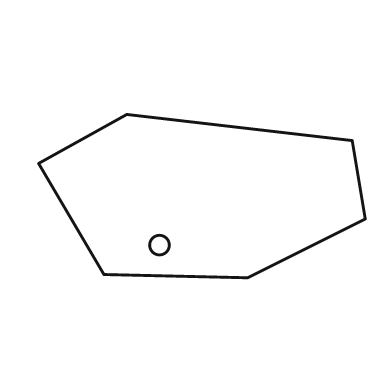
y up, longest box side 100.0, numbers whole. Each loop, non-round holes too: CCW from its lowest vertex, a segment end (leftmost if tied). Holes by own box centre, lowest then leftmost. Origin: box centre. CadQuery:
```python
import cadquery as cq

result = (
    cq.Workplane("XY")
    .moveTo(14.0, -25.0)
    .lineTo(50.0, -7.0)
    .lineTo(46.0, 17.0)
    .lineTo(-23.0, 25.0)
    .lineTo(-50.0, 10.0)
    .lineTo(-30.0, -24.0)
    .close()
    .moveTo(-13.0, -15.0)
    .circle(3.0)
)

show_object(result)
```